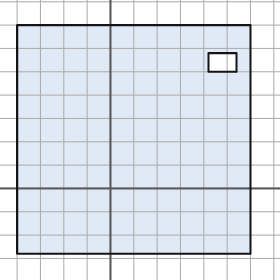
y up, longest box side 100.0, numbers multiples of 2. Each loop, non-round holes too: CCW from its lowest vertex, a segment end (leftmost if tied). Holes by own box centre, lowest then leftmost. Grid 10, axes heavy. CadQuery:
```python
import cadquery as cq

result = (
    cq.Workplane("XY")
    .moveTo(-40.0, -28.0)
    .lineTo(60.0, -28.0)
    .lineTo(60.0, 70.0)
    .lineTo(-40.0, 70.0)
    .close()
    .moveTo(42.0, 50.0)
    .lineTo(54.0, 50.0)
    .lineTo(54.0, 58.0)
    .lineTo(42.0, 58.0)
    .close()
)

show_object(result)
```